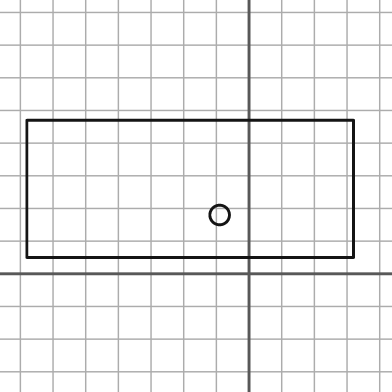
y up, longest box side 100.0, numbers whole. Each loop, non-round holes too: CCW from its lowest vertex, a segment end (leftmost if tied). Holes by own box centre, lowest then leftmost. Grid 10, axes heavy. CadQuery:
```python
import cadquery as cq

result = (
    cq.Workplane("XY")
    .moveTo(-68.0, 5.0)
    .lineTo(32.0, 5.0)
    .lineTo(32.0, 47.0)
    .lineTo(-68.0, 47.0)
    .close()
    .moveTo(-9.0, 18.0)
    .circle(3.0)
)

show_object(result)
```